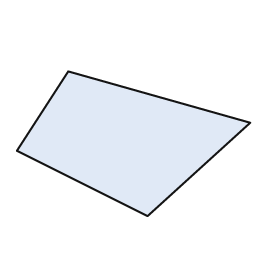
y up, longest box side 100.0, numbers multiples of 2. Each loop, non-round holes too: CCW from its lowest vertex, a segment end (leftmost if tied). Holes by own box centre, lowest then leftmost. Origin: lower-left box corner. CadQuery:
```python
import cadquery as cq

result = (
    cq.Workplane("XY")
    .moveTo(56.0, 0.0)
    .lineTo(100.0, 40.0)
    .lineTo(22.0, 62.0)
    .lineTo(0.0, 28.0)
    .close()
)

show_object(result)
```